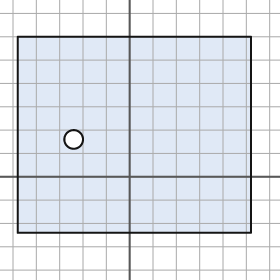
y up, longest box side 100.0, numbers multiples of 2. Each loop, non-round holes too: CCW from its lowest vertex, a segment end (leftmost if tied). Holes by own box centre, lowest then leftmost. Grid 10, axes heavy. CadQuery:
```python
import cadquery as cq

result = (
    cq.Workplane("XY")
    .moveTo(-48.0, -24.0)
    .lineTo(52.0, -24.0)
    .lineTo(52.0, 60.0)
    .lineTo(-48.0, 60.0)
    .close()
    .moveTo(-24.0, 16.0)
    .circle(4.0)
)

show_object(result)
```